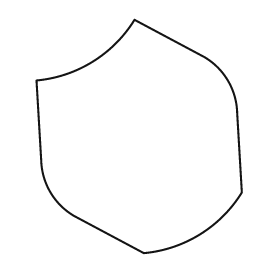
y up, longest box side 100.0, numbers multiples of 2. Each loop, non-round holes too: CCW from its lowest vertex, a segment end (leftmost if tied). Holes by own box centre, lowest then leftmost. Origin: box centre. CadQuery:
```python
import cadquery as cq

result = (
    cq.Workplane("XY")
    .moveTo(2.0, -50.0)
    .threePointArc((26.0, -42.0), (44.0, -24.0))
    .lineTo(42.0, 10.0)
    .threePointArc((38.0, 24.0), (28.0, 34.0))
    .lineTo(-2.0, 50.0)
    .threePointArc((-20.0, 32.0), (-44.0, 24.0))
    .lineTo(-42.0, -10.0)
    .threePointArc((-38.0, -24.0), (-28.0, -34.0))
    .close()
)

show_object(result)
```